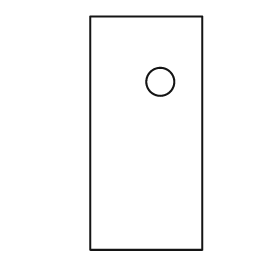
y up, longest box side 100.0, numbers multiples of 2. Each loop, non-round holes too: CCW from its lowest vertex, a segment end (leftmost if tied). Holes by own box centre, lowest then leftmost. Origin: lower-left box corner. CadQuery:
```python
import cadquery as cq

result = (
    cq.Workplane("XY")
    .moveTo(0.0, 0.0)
    .lineTo(48.0, 0.0)
    .lineTo(48.0, 100.0)
    .lineTo(0.0, 100.0)
    .close()
    .moveTo(30.0, 72.0)
    .circle(6.0)
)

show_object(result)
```